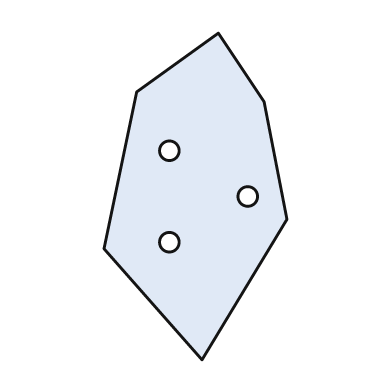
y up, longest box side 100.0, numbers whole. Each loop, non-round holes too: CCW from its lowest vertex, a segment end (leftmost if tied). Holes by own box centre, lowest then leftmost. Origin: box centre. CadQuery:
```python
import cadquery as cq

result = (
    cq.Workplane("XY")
    .moveTo(2.0, -50.0)
    .lineTo(28.0, -7.0)
    .lineTo(21.0, 29.0)
    .lineTo(7.0, 50.0)
    .lineTo(-18.0, 32.0)
    .lineTo(-28.0, -16.0)
    .close()
    .moveTo(-8.0, -14.0)
    .circle(3.0)
    .moveTo(16.0, 0.0)
    .circle(3.0)
    .moveTo(-8.0, 14.0)
    .circle(3.0)
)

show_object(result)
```